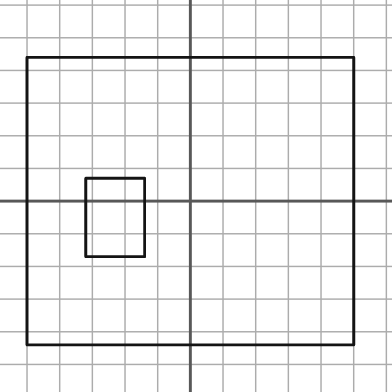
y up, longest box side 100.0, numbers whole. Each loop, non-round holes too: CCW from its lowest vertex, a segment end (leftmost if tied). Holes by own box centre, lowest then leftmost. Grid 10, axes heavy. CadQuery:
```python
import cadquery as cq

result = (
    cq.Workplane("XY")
    .moveTo(-50.0, -44.0)
    .lineTo(50.0, -44.0)
    .lineTo(50.0, 44.0)
    .lineTo(-50.0, 44.0)
    .close()
    .moveTo(-32.0, -17.0)
    .lineTo(-14.0, -17.0)
    .lineTo(-14.0, 7.0)
    .lineTo(-32.0, 7.0)
    .close()
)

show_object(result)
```